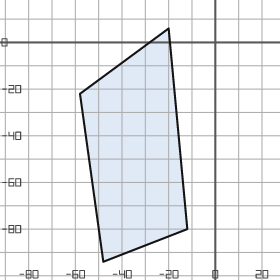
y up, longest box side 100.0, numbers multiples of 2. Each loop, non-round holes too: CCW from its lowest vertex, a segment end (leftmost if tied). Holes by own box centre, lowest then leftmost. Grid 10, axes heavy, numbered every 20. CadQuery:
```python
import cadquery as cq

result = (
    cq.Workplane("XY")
    .moveTo(-48.0, -94.0)
    .lineTo(-12.0, -80.0)
    .lineTo(-20.0, 6.0)
    .lineTo(-58.0, -22.0)
    .close()
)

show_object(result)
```